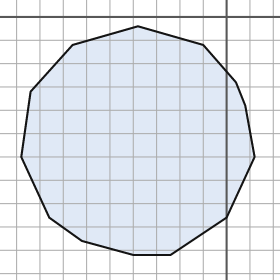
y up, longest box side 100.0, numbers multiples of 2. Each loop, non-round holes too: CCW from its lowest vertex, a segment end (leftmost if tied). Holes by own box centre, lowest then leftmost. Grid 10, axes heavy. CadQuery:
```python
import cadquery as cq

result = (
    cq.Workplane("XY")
    .moveTo(-40.0, -102.0)
    .lineTo(-24.0, -102.0)
    .lineTo(0.0, -86.0)
    .lineTo(12.0, -60.0)
    .lineTo(8.0, -38.0)
    .lineTo(4.0, -28.0)
    .lineTo(-10.0, -12.0)
    .lineTo(-38.0, -4.0)
    .lineTo(-66.0, -12.0)
    .lineTo(-84.0, -32.0)
    .lineTo(-88.0, -60.0)
    .lineTo(-76.0, -86.0)
    .lineTo(-62.0, -96.0)
    .close()
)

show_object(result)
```